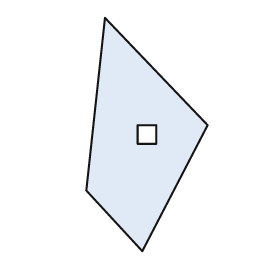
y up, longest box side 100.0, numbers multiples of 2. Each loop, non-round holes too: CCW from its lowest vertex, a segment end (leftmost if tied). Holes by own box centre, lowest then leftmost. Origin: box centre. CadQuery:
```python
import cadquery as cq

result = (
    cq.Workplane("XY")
    .moveTo(-2.0, -50.0)
    .lineTo(26.0, 4.0)
    .lineTo(-18.0, 50.0)
    .lineTo(-26.0, -24.0)
    .close()
    .moveTo(-4.0, -4.0)
    .lineTo(4.0, -4.0)
    .lineTo(4.0, 4.0)
    .lineTo(-4.0, 4.0)
    .close()
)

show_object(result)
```